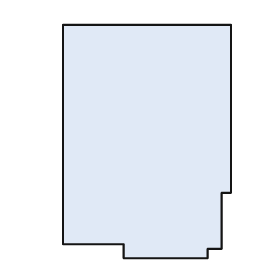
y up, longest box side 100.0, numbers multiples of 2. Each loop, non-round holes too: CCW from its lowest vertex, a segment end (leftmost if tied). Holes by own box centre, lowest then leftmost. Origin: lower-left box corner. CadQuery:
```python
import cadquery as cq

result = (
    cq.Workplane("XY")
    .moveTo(26.0, 0.0)
    .lineTo(62.0, 0.0)
    .lineTo(62.0, 4.0)
    .lineTo(68.0, 4.0)
    .lineTo(68.0, 28.0)
    .lineTo(72.0, 28.0)
    .lineTo(72.0, 100.0)
    .lineTo(0.0, 100.0)
    .lineTo(0.0, 6.0)
    .lineTo(26.0, 6.0)
    .close()
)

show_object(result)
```